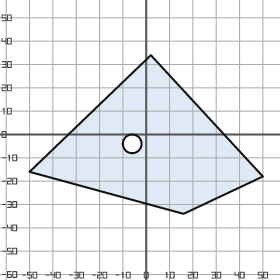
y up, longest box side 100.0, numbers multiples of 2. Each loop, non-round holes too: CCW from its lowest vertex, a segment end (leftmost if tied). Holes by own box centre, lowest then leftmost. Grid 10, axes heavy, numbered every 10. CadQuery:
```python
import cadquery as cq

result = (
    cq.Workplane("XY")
    .moveTo(16.0, -34.0)
    .lineTo(50.0, -18.0)
    .lineTo(2.0, 34.0)
    .lineTo(-50.0, -16.0)
    .close()
    .moveTo(-6.0, -4.0)
    .circle(4.0)
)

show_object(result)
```